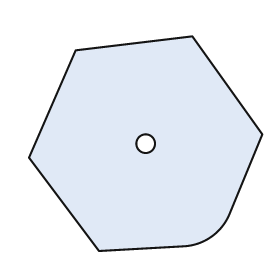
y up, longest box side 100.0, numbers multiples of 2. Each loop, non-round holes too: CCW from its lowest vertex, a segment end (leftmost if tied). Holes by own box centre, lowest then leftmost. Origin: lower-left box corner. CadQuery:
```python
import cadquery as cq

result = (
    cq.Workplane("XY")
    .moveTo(30.0, 0.0)
    .lineTo(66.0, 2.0)
    .threePointArc((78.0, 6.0), (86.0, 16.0))
    .lineTo(100.0, 50.0)
    .lineTo(70.0, 92.0)
    .lineTo(20.0, 86.0)
    .lineTo(0.0, 40.0)
    .close()
    .moveTo(50.0, 46.0)
    .circle(4.0)
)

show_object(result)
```